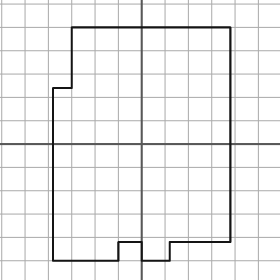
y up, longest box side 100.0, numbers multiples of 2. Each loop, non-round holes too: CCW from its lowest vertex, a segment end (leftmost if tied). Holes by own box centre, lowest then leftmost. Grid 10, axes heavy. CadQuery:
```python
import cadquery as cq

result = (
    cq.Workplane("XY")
    .moveTo(-38.0, -50.0)
    .lineTo(-10.0, -50.0)
    .lineTo(-10.0, -42.0)
    .lineTo(0.0, -42.0)
    .lineTo(0.0, -50.0)
    .lineTo(12.0, -50.0)
    .lineTo(12.0, -42.0)
    .lineTo(38.0, -42.0)
    .lineTo(38.0, 50.0)
    .lineTo(-30.0, 50.0)
    .lineTo(-30.0, 24.0)
    .lineTo(-38.0, 24.0)
    .close()
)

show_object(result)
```